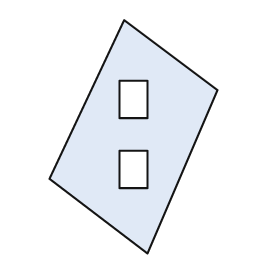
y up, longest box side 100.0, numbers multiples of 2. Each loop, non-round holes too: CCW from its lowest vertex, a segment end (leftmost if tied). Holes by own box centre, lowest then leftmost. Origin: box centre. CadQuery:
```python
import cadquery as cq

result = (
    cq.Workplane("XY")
    .moveTo(6.0, -50.0)
    .lineTo(36.0, 20.0)
    .lineTo(-4.0, 50.0)
    .lineTo(-36.0, -18.0)
    .close()
    .moveTo(-6.0, -22.0)
    .lineTo(6.0, -22.0)
    .lineTo(6.0, -6.0)
    .lineTo(-6.0, -6.0)
    .close()
    .moveTo(-6.0, 8.0)
    .lineTo(6.0, 8.0)
    .lineTo(6.0, 24.0)
    .lineTo(-6.0, 24.0)
    .close()
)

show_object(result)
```